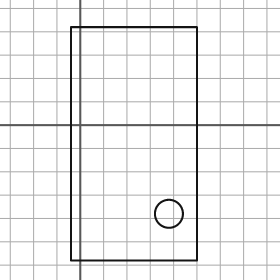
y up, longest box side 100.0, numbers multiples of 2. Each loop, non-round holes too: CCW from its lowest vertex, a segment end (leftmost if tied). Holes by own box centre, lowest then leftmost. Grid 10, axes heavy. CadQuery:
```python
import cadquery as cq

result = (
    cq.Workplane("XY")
    .moveTo(-4.0, -58.0)
    .lineTo(50.0, -58.0)
    .lineTo(50.0, 42.0)
    .lineTo(-4.0, 42.0)
    .close()
    .moveTo(38.0, -38.0)
    .circle(6.0)
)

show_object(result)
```